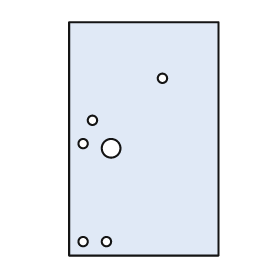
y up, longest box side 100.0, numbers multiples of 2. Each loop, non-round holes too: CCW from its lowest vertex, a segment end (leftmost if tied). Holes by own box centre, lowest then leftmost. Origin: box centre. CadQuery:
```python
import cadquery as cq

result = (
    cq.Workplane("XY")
    .moveTo(-32.0, -50.0)
    .lineTo(32.0, -50.0)
    .lineTo(32.0, 50.0)
    .lineTo(-32.0, 50.0)
    .close()
    .moveTo(-26.0, -44.0)
    .circle(2.0)
    .moveTo(-16.0, -44.0)
    .circle(2.0)
    .moveTo(-14.0, -4.0)
    .circle(4.0)
    .moveTo(-26.0, -2.0)
    .circle(2.0)
    .moveTo(-22.0, 8.0)
    .circle(2.0)
    .moveTo(8.0, 26.0)
    .circle(2.0)
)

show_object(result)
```